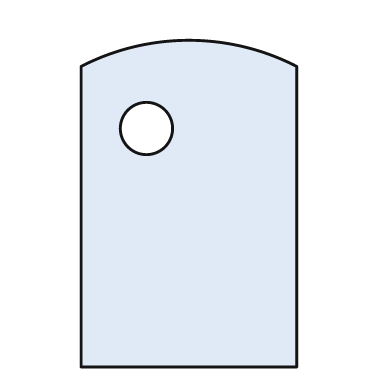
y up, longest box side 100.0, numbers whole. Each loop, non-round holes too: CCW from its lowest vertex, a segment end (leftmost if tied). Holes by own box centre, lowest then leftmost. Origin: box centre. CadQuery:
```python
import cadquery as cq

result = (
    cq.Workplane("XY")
    .moveTo(-33.0, -50.0)
    .lineTo(33.0, -50.0)
    .lineTo(33.0, 42.0)
    .threePointArc((0.0, 50.0), (-33.0, 42.0))
    .close()
    .moveTo(-13.0, 23.0)
    .circle(8.0)
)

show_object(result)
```